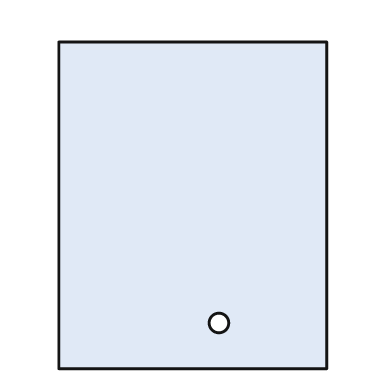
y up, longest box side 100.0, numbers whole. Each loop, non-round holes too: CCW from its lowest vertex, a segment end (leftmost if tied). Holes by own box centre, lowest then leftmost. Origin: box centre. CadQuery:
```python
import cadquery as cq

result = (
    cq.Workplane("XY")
    .moveTo(-41.0, -50.0)
    .lineTo(41.0, -50.0)
    .lineTo(41.0, 50.0)
    .lineTo(-41.0, 50.0)
    .close()
    .moveTo(8.0, -36.0)
    .circle(3.0)
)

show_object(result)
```